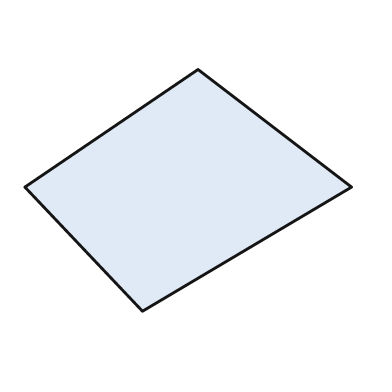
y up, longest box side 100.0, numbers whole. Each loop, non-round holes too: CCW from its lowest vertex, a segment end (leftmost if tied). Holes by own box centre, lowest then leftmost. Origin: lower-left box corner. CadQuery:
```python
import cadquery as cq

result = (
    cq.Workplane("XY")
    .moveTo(36.0, 0.0)
    .lineTo(100.0, 38.0)
    .lineTo(53.0, 74.0)
    .lineTo(0.0, 38.0)
    .close()
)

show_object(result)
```